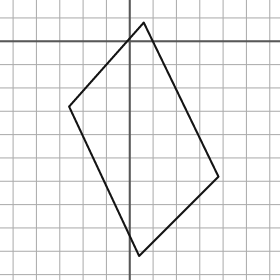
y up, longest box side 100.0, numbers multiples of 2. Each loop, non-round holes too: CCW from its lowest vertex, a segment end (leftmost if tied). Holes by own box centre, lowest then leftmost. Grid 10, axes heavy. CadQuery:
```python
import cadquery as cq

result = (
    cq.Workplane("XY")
    .moveTo(4.0, -92.0)
    .lineTo(38.0, -58.0)
    .lineTo(6.0, 8.0)
    .lineTo(-26.0, -28.0)
    .close()
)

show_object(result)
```